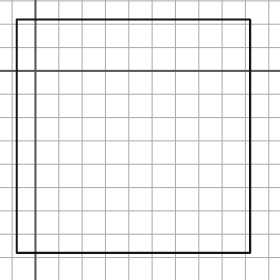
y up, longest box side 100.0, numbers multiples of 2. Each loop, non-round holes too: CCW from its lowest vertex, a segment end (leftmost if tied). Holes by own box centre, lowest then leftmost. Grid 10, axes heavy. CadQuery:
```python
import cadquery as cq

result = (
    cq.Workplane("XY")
    .moveTo(-8.0, -78.0)
    .lineTo(92.0, -78.0)
    .lineTo(92.0, 22.0)
    .lineTo(-8.0, 22.0)
    .close()
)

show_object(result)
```